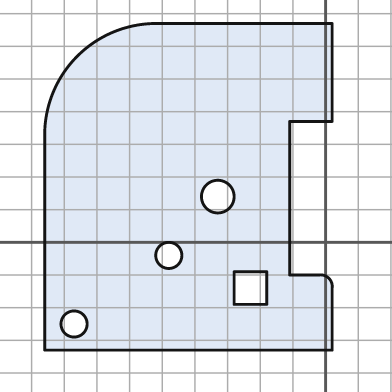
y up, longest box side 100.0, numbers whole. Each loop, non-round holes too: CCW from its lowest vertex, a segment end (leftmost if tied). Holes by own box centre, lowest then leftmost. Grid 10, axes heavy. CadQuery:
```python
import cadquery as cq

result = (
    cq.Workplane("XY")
    .moveTo(-86.0, -33.0)
    .lineTo(2.0, -33.0)
    .lineTo(2.0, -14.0)
    .threePointArc((1.0, -11.0), (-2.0, -10.0))
    .lineTo(-11.0, -10.0)
    .lineTo(-11.0, 37.0)
    .lineTo(2.0, 37.0)
    .lineTo(2.0, 67.0)
    .lineTo(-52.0, 67.0)
    .threePointArc((-76.0, 57.0), (-86.0, 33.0))
    .close()
    .moveTo(-77.0, -25.0)
    .circle(4.0)
    .moveTo(-28.0, -19.0)
    .lineTo(-18.0, -19.0)
    .lineTo(-18.0, -9.0)
    .lineTo(-28.0, -9.0)
    .close()
    .moveTo(-48.0, -4.0)
    .circle(4.0)
    .moveTo(-33.0, 14.0)
    .circle(5.0)
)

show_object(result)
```